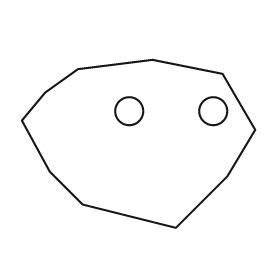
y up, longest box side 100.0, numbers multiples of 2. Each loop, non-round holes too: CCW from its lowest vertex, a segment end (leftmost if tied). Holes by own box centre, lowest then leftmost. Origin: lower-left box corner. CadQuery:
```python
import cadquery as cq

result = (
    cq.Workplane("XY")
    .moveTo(66.0, 0.0)
    .lineTo(88.0, 22.0)
    .lineTo(100.0, 42.0)
    .lineTo(86.0, 66.0)
    .lineTo(56.0, 72.0)
    .lineTo(24.0, 68.0)
    .lineTo(10.0, 58.0)
    .lineTo(0.0, 46.0)
    .lineTo(12.0, 24.0)
    .lineTo(26.0, 10.0)
    .close()
    .moveTo(46.0, 50.0)
    .circle(6.0)
    .moveTo(82.0, 50.0)
    .circle(6.0)
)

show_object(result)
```